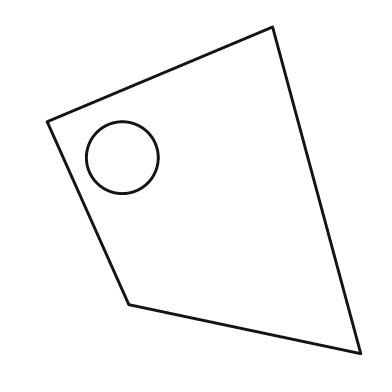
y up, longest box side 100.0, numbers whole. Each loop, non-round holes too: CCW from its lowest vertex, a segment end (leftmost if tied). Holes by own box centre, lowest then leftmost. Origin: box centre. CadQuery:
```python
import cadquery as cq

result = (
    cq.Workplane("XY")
    .moveTo(48.0, -50.0)
    .lineTo(21.0, 50.0)
    .lineTo(-48.0, 21.0)
    .lineTo(-23.0, -35.0)
    .close()
    .moveTo(-25.0, 10.0)
    .circle(11.0)
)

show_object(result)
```